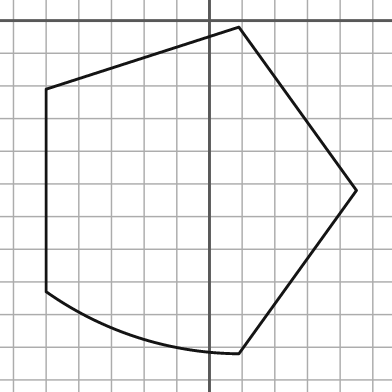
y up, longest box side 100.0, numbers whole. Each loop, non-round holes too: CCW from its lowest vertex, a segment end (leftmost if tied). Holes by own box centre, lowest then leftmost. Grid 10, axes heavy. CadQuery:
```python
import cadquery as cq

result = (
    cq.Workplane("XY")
    .moveTo(9.0, -102.0)
    .lineTo(45.0, -52.0)
    .lineTo(9.0, -2.0)
    .lineTo(-50.0, -21.0)
    .lineTo(-50.0, -83.0)
    .threePointArc((-22.0, -97.0), (9.0, -102.0))
    .close()
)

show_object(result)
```